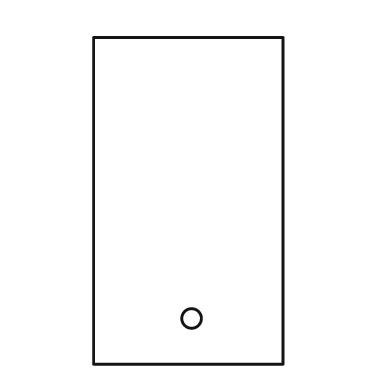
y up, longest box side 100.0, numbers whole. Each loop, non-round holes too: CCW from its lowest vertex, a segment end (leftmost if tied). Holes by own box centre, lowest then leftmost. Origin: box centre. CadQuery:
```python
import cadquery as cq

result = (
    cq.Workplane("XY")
    .moveTo(-29.0, -50.0)
    .lineTo(29.0, -50.0)
    .lineTo(29.0, 50.0)
    .lineTo(-29.0, 50.0)
    .close()
    .moveTo(1.0, -36.0)
    .circle(3.0)
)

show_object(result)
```